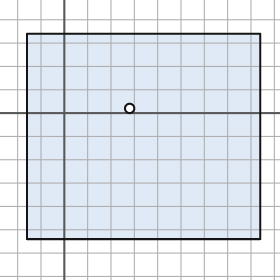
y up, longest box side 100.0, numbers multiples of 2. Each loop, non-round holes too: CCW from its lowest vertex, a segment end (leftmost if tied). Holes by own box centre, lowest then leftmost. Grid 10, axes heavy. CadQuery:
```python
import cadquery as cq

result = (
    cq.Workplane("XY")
    .moveTo(-16.0, -54.0)
    .lineTo(84.0, -54.0)
    .lineTo(84.0, 34.0)
    .lineTo(-16.0, 34.0)
    .close()
    .moveTo(28.0, 2.0)
    .circle(2.0)
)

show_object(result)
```